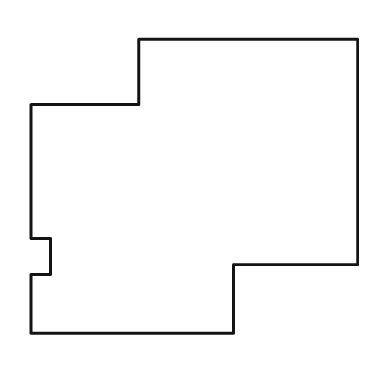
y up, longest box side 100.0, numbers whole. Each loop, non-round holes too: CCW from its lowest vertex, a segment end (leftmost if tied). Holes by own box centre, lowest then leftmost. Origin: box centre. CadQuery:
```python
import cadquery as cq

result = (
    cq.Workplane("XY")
    .moveTo(-50.0, -45.0)
    .lineTo(12.0, -45.0)
    .lineTo(12.0, -24.0)
    .lineTo(50.0, -24.0)
    .lineTo(50.0, 45.0)
    .lineTo(-17.0, 45.0)
    .lineTo(-17.0, 25.0)
    .lineTo(-50.0, 25.0)
    .lineTo(-50.0, -16.0)
    .lineTo(-44.0, -16.0)
    .lineTo(-44.0, -27.0)
    .lineTo(-50.0, -27.0)
    .close()
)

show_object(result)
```